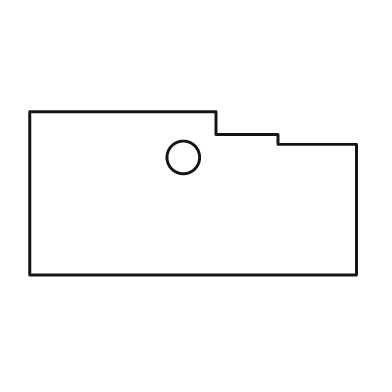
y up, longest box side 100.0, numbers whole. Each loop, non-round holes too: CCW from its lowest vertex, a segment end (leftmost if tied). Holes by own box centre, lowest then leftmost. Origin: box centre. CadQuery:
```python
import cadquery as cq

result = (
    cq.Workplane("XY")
    .moveTo(-50.0, -25.0)
    .lineTo(50.0, -25.0)
    .lineTo(50.0, 15.0)
    .lineTo(26.0, 15.0)
    .lineTo(26.0, 18.0)
    .lineTo(7.0, 18.0)
    .lineTo(7.0, 25.0)
    .lineTo(-50.0, 25.0)
    .close()
    .moveTo(-3.0, 11.0)
    .circle(5.0)
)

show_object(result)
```